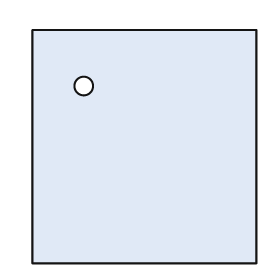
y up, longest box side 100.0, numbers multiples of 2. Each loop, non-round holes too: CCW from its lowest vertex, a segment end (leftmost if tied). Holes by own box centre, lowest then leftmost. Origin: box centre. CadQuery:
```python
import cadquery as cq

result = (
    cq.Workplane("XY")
    .moveTo(-48.0, -50.0)
    .lineTo(48.0, -50.0)
    .lineTo(48.0, 50.0)
    .lineTo(-48.0, 50.0)
    .close()
    .moveTo(-26.0, 26.0)
    .circle(4.0)
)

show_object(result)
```